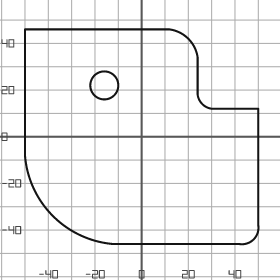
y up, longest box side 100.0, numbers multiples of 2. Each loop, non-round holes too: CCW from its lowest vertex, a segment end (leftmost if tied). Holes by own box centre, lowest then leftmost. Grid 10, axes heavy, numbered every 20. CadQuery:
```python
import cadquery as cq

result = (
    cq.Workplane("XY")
    .moveTo(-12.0, -46.0)
    .lineTo(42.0, -46.0)
    .threePointArc((48.0, -44.0), (50.0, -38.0))
    .lineTo(50.0, 12.0)
    .lineTo(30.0, 12.0)
    .threePointArc((26.0, 14.0), (24.0, 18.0))
    .lineTo(24.0, 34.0)
    .threePointArc((20.0, 42.0), (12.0, 46.0))
    .lineTo(-50.0, 46.0)
    .lineTo(-50.0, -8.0)
    .threePointArc((-38.0, -34.0), (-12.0, -46.0))
    .close()
    .moveTo(-16.0, 22.0)
    .circle(6.0)
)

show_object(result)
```